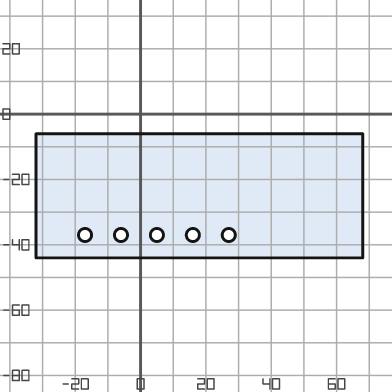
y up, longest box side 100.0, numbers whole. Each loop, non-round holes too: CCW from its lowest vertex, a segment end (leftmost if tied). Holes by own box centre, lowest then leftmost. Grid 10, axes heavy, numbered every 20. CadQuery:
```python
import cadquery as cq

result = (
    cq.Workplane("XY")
    .moveTo(-32.0, -44.0)
    .lineTo(68.0, -44.0)
    .lineTo(68.0, -6.0)
    .lineTo(-32.0, -6.0)
    .close()
    .moveTo(-17.0, -37.0)
    .circle(2.0)
    .moveTo(-6.0, -37.0)
    .circle(2.0)
    .moveTo(5.0, -37.0)
    .circle(2.0)
    .moveTo(16.0, -37.0)
    .circle(2.0)
    .moveTo(27.0, -37.0)
    .circle(2.0)
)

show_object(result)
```